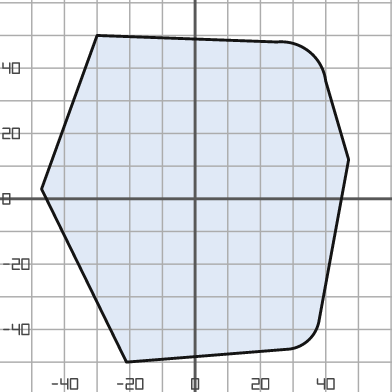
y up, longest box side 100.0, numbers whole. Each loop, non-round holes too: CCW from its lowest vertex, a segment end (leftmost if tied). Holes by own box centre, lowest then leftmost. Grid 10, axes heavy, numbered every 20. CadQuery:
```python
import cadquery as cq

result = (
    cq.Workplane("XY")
    .moveTo(-21.0, -50.0)
    .lineTo(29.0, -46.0)
    .threePointArc((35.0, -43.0), (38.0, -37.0))
    .lineTo(47.0, 12.0)
    .lineTo(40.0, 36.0)
    .threePointArc((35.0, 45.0), (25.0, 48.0))
    .lineTo(-30.0, 50.0)
    .lineTo(-47.0, 3.0)
    .close()
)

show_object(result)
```